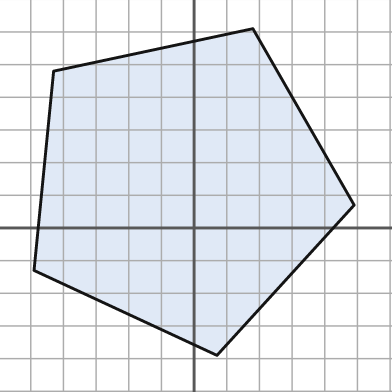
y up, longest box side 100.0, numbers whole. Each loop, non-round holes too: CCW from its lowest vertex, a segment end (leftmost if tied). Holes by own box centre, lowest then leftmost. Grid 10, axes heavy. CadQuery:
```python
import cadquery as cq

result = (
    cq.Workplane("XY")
    .moveTo(7.0, -39.0)
    .lineTo(49.0, 7.0)
    .lineTo(18.0, 61.0)
    .lineTo(-43.0, 48.0)
    .lineTo(-49.0, -13.0)
    .close()
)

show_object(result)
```